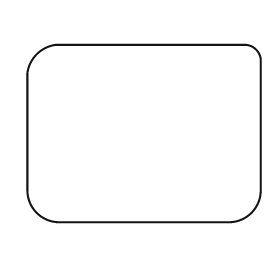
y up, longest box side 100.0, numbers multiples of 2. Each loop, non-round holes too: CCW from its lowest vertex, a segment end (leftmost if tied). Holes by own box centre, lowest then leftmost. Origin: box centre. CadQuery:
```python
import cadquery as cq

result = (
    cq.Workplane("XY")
    .moveTo(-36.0, -38.0)
    .lineTo(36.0, -38.0)
    .threePointArc((46.0, -34.0), (50.0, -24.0))
    .lineTo(50.0, 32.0)
    .threePointArc((48.0, 36.0), (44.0, 38.0))
    .lineTo(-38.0, 38.0)
    .threePointArc((-46.0, 34.0), (-50.0, 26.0))
    .lineTo(-50.0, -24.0)
    .threePointArc((-46.0, -34.0), (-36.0, -38.0))
    .close()
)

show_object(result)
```